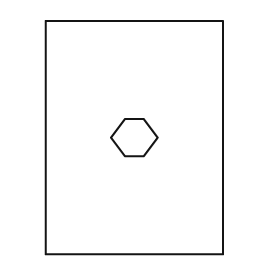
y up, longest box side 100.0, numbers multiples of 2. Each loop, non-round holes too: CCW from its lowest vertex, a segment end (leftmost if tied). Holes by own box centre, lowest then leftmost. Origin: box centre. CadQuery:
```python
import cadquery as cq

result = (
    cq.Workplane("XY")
    .moveTo(-38.0, -50.0)
    .lineTo(38.0, -50.0)
    .lineTo(38.0, 50.0)
    .lineTo(-38.0, 50.0)
    .close()
    .moveTo(-4.0, -8.0)
    .lineTo(4.0, -8.0)
    .lineTo(10.0, 0.0)
    .lineTo(4.0, 8.0)
    .lineTo(-4.0, 8.0)
    .lineTo(-10.0, 0.0)
    .close()
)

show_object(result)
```